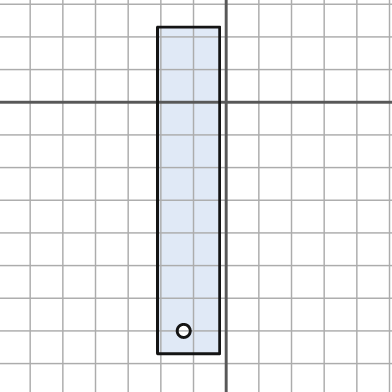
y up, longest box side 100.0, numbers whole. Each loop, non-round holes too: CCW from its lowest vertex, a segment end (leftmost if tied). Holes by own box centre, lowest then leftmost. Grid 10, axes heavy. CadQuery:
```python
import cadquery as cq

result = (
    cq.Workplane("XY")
    .moveTo(-21.0, -77.0)
    .lineTo(-2.0, -77.0)
    .lineTo(-2.0, 23.0)
    .lineTo(-21.0, 23.0)
    .close()
    .moveTo(-13.0, -70.0)
    .circle(2.0)
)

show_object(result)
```